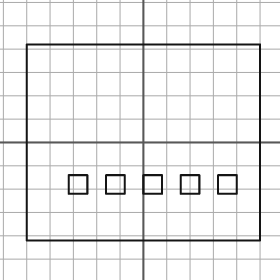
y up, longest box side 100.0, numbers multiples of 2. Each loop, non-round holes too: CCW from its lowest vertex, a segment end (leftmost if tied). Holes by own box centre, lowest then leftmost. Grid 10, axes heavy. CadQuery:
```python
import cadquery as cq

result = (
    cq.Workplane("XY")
    .moveTo(-50.0, -42.0)
    .lineTo(50.0, -42.0)
    .lineTo(50.0, 42.0)
    .lineTo(-50.0, 42.0)
    .close()
    .moveTo(-32.0, -22.0)
    .lineTo(-24.0, -22.0)
    .lineTo(-24.0, -14.0)
    .lineTo(-32.0, -14.0)
    .close()
    .moveTo(-16.0, -22.0)
    .lineTo(-8.0, -22.0)
    .lineTo(-8.0, -14.0)
    .lineTo(-16.0, -14.0)
    .close()
    .moveTo(0.0, -22.0)
    .lineTo(8.0, -22.0)
    .lineTo(8.0, -14.0)
    .lineTo(0.0, -14.0)
    .close()
    .moveTo(16.0, -22.0)
    .lineTo(24.0, -22.0)
    .lineTo(24.0, -14.0)
    .lineTo(16.0, -14.0)
    .close()
    .moveTo(32.0, -22.0)
    .lineTo(40.0, -22.0)
    .lineTo(40.0, -14.0)
    .lineTo(32.0, -14.0)
    .close()
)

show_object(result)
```